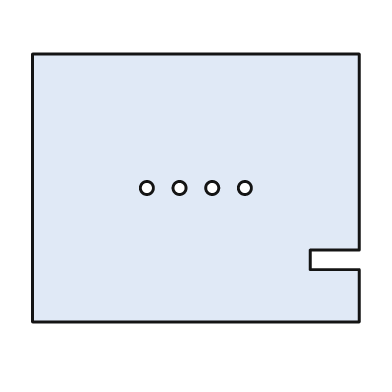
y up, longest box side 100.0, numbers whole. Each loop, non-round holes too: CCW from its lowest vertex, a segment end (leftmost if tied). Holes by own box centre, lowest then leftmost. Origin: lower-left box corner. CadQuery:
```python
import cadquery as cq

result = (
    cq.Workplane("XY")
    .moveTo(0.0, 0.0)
    .lineTo(100.0, 0.0)
    .lineTo(100.0, 16.0)
    .lineTo(85.0, 16.0)
    .lineTo(85.0, 22.0)
    .lineTo(100.0, 22.0)
    .lineTo(100.0, 82.0)
    .lineTo(0.0, 82.0)
    .close()
    .moveTo(35.0, 41.0)
    .circle(2.0)
    .moveTo(45.0, 41.0)
    .circle(2.0)
    .moveTo(55.0, 41.0)
    .circle(2.0)
    .moveTo(65.0, 41.0)
    .circle(2.0)
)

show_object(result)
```